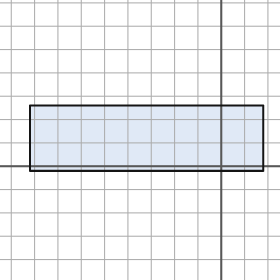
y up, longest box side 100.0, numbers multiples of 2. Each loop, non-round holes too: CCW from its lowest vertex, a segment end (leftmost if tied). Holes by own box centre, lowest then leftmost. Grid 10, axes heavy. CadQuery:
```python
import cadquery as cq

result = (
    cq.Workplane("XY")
    .moveTo(-82.0, -2.0)
    .lineTo(18.0, -2.0)
    .lineTo(18.0, 26.0)
    .lineTo(-82.0, 26.0)
    .close()
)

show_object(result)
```